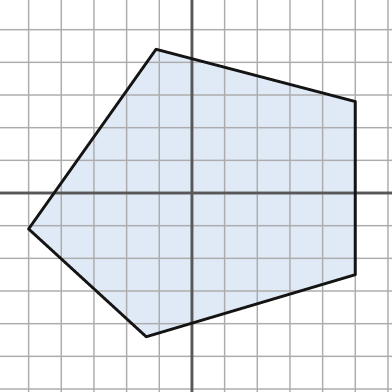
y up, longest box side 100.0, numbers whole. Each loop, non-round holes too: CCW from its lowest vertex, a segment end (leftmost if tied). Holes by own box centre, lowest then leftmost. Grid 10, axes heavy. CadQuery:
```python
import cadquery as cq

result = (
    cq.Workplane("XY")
    .moveTo(-14.0, -44.0)
    .lineTo(50.0, -25.0)
    .lineTo(50.0, 28.0)
    .lineTo(-11.0, 44.0)
    .lineTo(-50.0, -11.0)
    .close()
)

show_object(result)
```